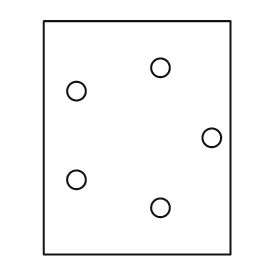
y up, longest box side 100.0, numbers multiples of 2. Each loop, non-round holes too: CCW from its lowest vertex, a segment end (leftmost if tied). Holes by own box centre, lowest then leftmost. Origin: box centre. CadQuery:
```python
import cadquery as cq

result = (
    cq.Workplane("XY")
    .moveTo(-40.0, -50.0)
    .lineTo(40.0, -50.0)
    .lineTo(40.0, 50.0)
    .lineTo(-40.0, 50.0)
    .close()
    .moveTo(10.0, -30.0)
    .circle(4.0)
    .moveTo(-26.0, -18.0)
    .circle(4.0)
    .moveTo(32.0, 0.0)
    .circle(4.0)
    .moveTo(-26.0, 20.0)
    .circle(4.0)
    .moveTo(10.0, 30.0)
    .circle(4.0)
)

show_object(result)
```